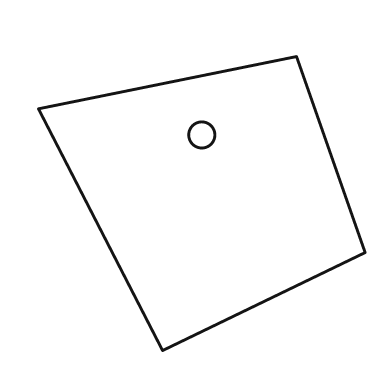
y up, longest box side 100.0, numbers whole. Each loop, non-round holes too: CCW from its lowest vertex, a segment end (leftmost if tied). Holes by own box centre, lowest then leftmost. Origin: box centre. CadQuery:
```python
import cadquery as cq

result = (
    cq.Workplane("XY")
    .moveTo(-12.0, -45.0)
    .lineTo(50.0, -15.0)
    .lineTo(29.0, 45.0)
    .lineTo(-50.0, 29.0)
    .close()
    .moveTo(0.0, 21.0)
    .circle(4.0)
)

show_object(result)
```